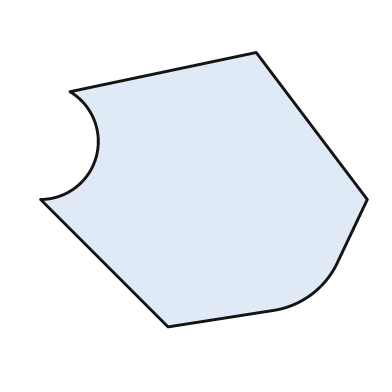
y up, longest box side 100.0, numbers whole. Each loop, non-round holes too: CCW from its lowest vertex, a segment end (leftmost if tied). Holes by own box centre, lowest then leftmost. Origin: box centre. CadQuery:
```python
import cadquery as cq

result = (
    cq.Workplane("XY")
    .moveTo(-11.0, -42.0)
    .lineTo(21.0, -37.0)
    .threePointArc((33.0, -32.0), (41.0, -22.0))
    .lineTo(50.0, -3.0)
    .lineTo(16.0, 42.0)
    .lineTo(-41.0, 30.0)
    .threePointArc((-33.0, 10.0), (-50.0, -3.0))
    .close()
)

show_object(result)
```